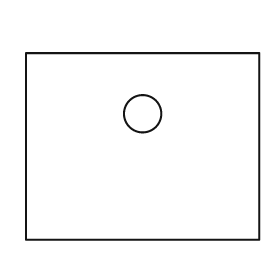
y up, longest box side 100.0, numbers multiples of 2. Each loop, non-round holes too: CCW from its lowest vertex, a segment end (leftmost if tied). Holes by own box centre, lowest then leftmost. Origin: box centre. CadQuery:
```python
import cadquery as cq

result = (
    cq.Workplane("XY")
    .moveTo(-50.0, -40.0)
    .lineTo(50.0, -40.0)
    .lineTo(50.0, 40.0)
    .lineTo(-50.0, 40.0)
    .close()
    .moveTo(0.0, 14.0)
    .circle(8.0)
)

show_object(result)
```